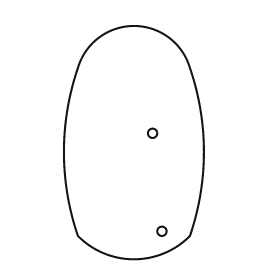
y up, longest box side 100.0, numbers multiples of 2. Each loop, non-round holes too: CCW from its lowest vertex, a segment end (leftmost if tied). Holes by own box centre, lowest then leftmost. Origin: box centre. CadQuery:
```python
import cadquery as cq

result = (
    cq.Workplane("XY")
    .moveTo(-24.0, -40.0)
    .threePointArc((0.0, -50.0), (24.0, -40.0))
    .threePointArc((30.0, -4.0), (24.0, 32.0))
    .threePointArc((0.0, 50.0), (-24.0, 32.0))
    .threePointArc((-30.0, -4.0), (-24.0, -40.0))
    .close()
    .moveTo(12.0, -38.0)
    .circle(2.0)
    .moveTo(8.0, 4.0)
    .circle(2.0)
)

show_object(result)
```